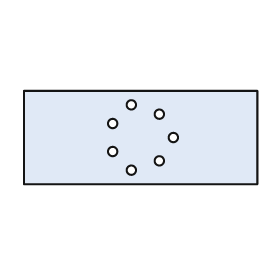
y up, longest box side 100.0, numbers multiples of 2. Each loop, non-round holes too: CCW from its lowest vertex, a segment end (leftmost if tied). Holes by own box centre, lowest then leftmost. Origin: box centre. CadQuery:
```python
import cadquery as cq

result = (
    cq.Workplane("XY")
    .moveTo(-50.0, -20.0)
    .lineTo(50.0, -20.0)
    .lineTo(50.0, 20.0)
    .lineTo(-50.0, 20.0)
    .close()
    .moveTo(-4.0, -14.0)
    .circle(2.0)
    .moveTo(8.0, -10.0)
    .circle(2.0)
    .moveTo(-12.0, -6.0)
    .circle(2.0)
    .moveTo(14.0, 0.0)
    .circle(2.0)
    .moveTo(-12.0, 6.0)
    .circle(2.0)
    .moveTo(8.0, 10.0)
    .circle(2.0)
    .moveTo(-4.0, 14.0)
    .circle(2.0)
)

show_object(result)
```